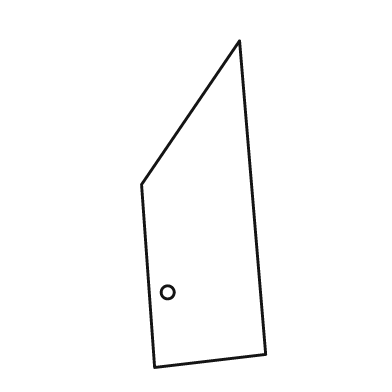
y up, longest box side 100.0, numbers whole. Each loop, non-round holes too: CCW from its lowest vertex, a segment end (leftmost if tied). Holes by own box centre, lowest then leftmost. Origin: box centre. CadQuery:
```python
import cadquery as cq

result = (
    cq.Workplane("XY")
    .moveTo(-15.0, -50.0)
    .lineTo(19.0, -46.0)
    .lineTo(11.0, 50.0)
    .lineTo(-19.0, 6.0)
    .close()
    .moveTo(-11.0, -27.0)
    .circle(2.0)
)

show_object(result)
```